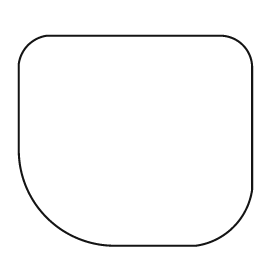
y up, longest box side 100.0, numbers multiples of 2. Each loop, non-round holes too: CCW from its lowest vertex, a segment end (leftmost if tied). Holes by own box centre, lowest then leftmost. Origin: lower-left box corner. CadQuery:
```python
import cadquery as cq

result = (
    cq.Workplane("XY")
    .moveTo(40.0, 0.0)
    .lineTo(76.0, 0.0)
    .threePointArc((92.0, 8.0), (100.0, 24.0))
    .lineTo(100.0, 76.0)
    .threePointArc((96.0, 86.0), (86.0, 90.0))
    .lineTo(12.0, 90.0)
    .threePointArc((4.0, 86.0), (0.0, 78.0))
    .lineTo(0.0, 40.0)
    .threePointArc((12.0, 12.0), (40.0, 0.0))
    .close()
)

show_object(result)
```